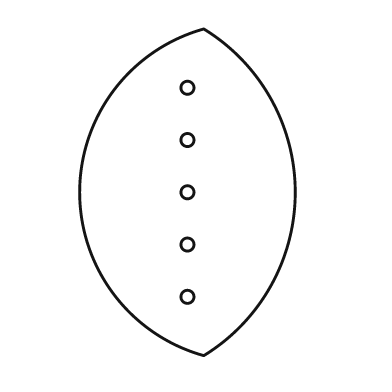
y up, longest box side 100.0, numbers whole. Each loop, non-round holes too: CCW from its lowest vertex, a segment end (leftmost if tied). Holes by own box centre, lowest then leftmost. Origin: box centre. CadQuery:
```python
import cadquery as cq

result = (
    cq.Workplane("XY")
    .moveTo(5.0, -50.0)
    .threePointArc((33.0, 0.0), (5.0, 50.0))
    .threePointArc((-33.0, 0.0), (5.0, -50.0))
    .close()
    .moveTo(0.0, -32.0)
    .circle(2.0)
    .moveTo(0.0, -16.0)
    .circle(2.0)
    .moveTo(0.0, 0.0)
    .circle(2.0)
    .moveTo(0.0, 16.0)
    .circle(2.0)
    .moveTo(0.0, 32.0)
    .circle(2.0)
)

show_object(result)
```